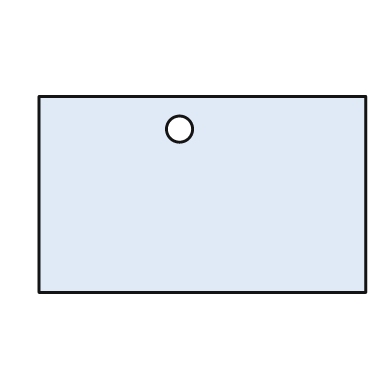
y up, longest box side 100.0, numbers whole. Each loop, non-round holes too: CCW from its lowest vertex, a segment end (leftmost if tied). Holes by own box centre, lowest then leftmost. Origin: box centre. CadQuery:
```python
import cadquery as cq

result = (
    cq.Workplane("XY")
    .moveTo(-50.0, -30.0)
    .lineTo(50.0, -30.0)
    .lineTo(50.0, 30.0)
    .lineTo(-50.0, 30.0)
    .close()
    .moveTo(-7.0, 20.0)
    .circle(4.0)
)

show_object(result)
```